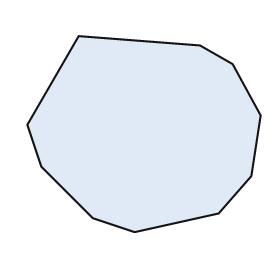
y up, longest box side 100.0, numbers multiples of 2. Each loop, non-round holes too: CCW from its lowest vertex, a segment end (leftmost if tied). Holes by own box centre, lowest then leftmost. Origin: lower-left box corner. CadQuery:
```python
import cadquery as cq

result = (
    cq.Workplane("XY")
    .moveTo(46.0, 0.0)
    .lineTo(82.0, 8.0)
    .lineTo(96.0, 24.0)
    .lineTo(100.0, 50.0)
    .lineTo(88.0, 72.0)
    .lineTo(74.0, 80.0)
    .lineTo(22.0, 84.0)
    .lineTo(0.0, 46.0)
    .lineTo(6.0, 28.0)
    .lineTo(28.0, 6.0)
    .close()
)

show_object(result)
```